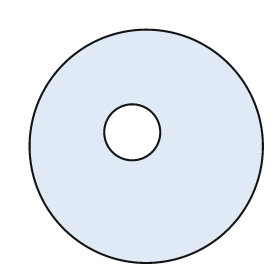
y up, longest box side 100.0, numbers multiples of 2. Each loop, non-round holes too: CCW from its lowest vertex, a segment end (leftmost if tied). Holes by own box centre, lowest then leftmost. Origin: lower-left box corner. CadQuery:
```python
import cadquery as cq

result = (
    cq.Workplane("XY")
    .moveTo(50.0, 50.0)
    .circle(50.0)
    .moveTo(44.0, 56.0)
    .circle(12.0)
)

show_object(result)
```